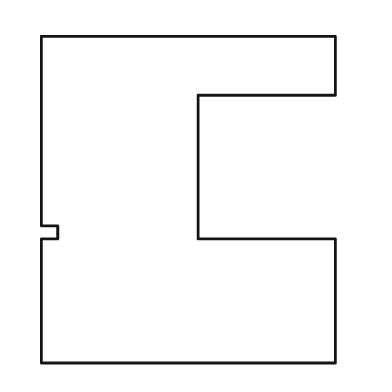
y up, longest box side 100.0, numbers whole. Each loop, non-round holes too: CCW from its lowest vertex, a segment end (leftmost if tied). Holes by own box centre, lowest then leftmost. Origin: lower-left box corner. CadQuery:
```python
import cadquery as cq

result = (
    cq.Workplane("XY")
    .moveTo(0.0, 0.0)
    .lineTo(90.0, 0.0)
    .lineTo(90.0, 38.0)
    .lineTo(48.0, 38.0)
    .lineTo(48.0, 82.0)
    .lineTo(90.0, 82.0)
    .lineTo(90.0, 100.0)
    .lineTo(0.0, 100.0)
    .lineTo(0.0, 42.0)
    .lineTo(5.0, 42.0)
    .lineTo(5.0, 38.0)
    .lineTo(0.0, 38.0)
    .close()
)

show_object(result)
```